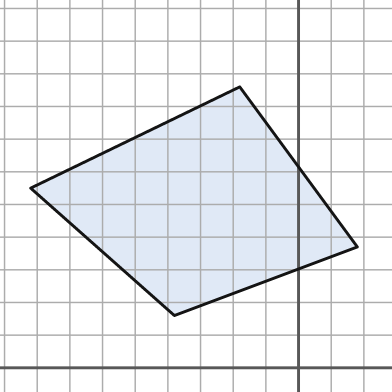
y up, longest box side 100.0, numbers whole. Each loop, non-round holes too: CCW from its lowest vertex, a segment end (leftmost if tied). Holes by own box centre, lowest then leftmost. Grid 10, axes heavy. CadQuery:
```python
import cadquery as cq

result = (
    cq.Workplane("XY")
    .moveTo(-38.0, 16.0)
    .lineTo(18.0, 37.0)
    .lineTo(-18.0, 86.0)
    .lineTo(-82.0, 55.0)
    .close()
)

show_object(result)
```